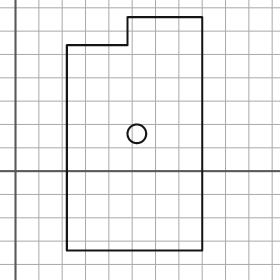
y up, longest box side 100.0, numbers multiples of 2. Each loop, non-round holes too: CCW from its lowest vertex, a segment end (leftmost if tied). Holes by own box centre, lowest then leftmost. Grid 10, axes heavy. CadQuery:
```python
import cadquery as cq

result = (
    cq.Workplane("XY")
    .moveTo(22.0, -34.0)
    .lineTo(80.0, -34.0)
    .lineTo(80.0, 66.0)
    .lineTo(48.0, 66.0)
    .lineTo(48.0, 54.0)
    .lineTo(22.0, 54.0)
    .close()
    .moveTo(52.0, 16.0)
    .circle(4.0)
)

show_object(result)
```